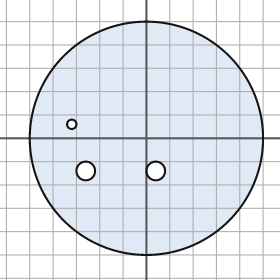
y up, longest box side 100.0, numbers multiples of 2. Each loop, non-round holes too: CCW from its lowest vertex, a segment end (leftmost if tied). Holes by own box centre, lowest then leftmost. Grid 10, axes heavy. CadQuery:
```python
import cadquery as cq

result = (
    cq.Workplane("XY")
    .moveTo(0.0, 0.0)
    .circle(50.0)
    .moveTo(-26.0, -14.0)
    .circle(4.0)
    .moveTo(4.0, -14.0)
    .circle(4.0)
    .moveTo(-32.0, 6.0)
    .circle(2.0)
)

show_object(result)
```